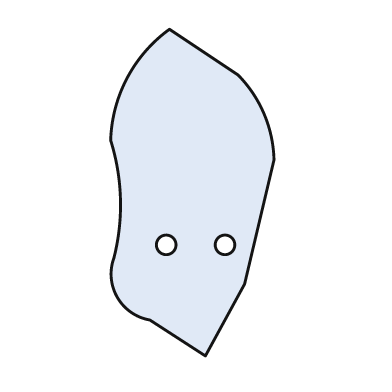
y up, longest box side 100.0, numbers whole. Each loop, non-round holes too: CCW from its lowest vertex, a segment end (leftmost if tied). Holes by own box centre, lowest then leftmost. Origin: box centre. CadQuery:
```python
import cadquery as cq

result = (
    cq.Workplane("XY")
    .moveTo(4.0, -50.0)
    .lineTo(16.0, -28.0)
    .lineTo(25.0, 10.0)
    .threePointArc((22.0, 24.0), (14.0, 36.0))
    .lineTo(-7.0, 50.0)
    .threePointArc((-20.0, 35.0), (-25.0, 16.0))
    .threePointArc((-22.0, -2.0), (-24.0, -20.0))
    .threePointArc((-23.0, -32.0), (-13.0, -39.0))
    .close()
    .moveTo(-8.0, -16.0)
    .circle(3.0)
    .moveTo(10.0, -16.0)
    .circle(3.0)
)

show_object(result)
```